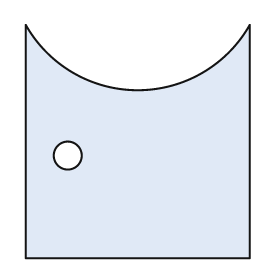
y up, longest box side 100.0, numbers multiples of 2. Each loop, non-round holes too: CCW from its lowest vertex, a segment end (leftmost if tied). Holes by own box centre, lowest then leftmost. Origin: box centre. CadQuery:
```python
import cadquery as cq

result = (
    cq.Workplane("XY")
    .moveTo(-48.0, -50.0)
    .lineTo(48.0, -50.0)
    .lineTo(48.0, 50.0)
    .threePointArc((0.0, 22.0), (-48.0, 50.0))
    .close()
    .moveTo(-30.0, -6.0)
    .circle(6.0)
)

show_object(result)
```